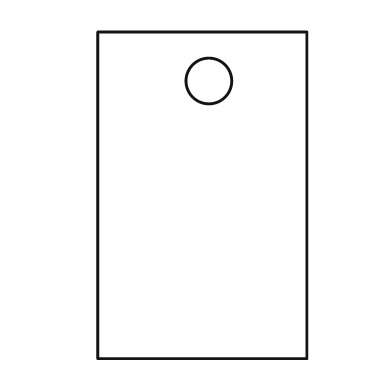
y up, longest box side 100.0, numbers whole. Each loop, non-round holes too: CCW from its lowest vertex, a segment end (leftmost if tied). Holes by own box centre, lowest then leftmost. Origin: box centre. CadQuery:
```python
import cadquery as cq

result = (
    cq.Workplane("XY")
    .moveTo(-32.0, -50.0)
    .lineTo(32.0, -50.0)
    .lineTo(32.0, 50.0)
    .lineTo(-32.0, 50.0)
    .close()
    .moveTo(2.0, 35.0)
    .circle(7.0)
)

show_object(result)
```